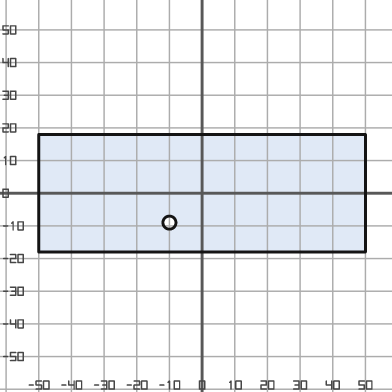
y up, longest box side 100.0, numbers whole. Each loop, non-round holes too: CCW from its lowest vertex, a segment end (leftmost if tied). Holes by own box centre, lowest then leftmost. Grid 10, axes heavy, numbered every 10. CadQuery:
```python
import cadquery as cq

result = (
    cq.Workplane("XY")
    .moveTo(-50.0, -18.0)
    .lineTo(50.0, -18.0)
    .lineTo(50.0, 18.0)
    .lineTo(-50.0, 18.0)
    .close()
    .moveTo(-10.0, -9.0)
    .circle(2.0)
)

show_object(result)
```